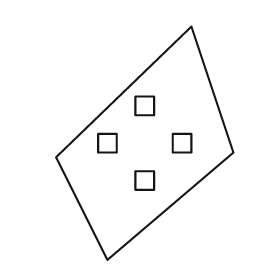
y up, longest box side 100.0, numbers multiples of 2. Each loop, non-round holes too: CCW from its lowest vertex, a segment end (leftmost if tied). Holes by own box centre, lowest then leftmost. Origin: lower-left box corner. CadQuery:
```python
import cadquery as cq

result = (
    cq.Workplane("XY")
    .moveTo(22.0, 0.0)
    .lineTo(76.0, 46.0)
    .lineTo(58.0, 100.0)
    .lineTo(0.0, 44.0)
    .close()
    .moveTo(34.0, 30.0)
    .lineTo(42.0, 30.0)
    .lineTo(42.0, 38.0)
    .lineTo(34.0, 38.0)
    .close()
    .moveTo(18.0, 46.0)
    .lineTo(26.0, 46.0)
    .lineTo(26.0, 54.0)
    .lineTo(18.0, 54.0)
    .close()
    .moveTo(50.0, 46.0)
    .lineTo(58.0, 46.0)
    .lineTo(58.0, 54.0)
    .lineTo(50.0, 54.0)
    .close()
    .moveTo(34.0, 62.0)
    .lineTo(42.0, 62.0)
    .lineTo(42.0, 70.0)
    .lineTo(34.0, 70.0)
    .close()
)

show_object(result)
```